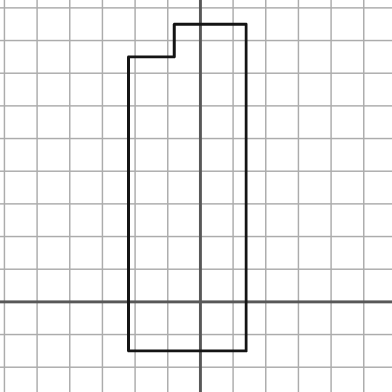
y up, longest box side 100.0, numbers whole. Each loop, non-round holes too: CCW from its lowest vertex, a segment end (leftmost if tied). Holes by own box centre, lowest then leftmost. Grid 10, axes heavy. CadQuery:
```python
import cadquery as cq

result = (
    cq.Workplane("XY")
    .moveTo(-22.0, -15.0)
    .lineTo(14.0, -15.0)
    .lineTo(14.0, 85.0)
    .lineTo(-8.0, 85.0)
    .lineTo(-8.0, 75.0)
    .lineTo(-22.0, 75.0)
    .close()
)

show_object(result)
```